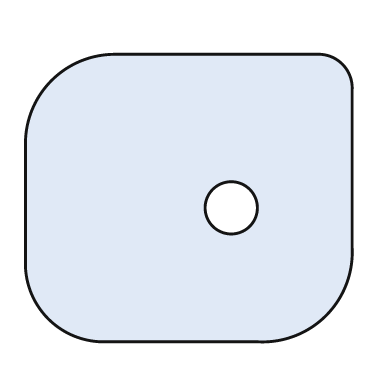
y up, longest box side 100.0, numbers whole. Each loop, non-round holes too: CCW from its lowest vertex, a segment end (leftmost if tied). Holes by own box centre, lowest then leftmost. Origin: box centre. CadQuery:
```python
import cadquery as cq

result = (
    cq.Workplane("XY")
    .moveTo(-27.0, -44.0)
    .lineTo(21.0, -44.0)
    .threePointArc((42.0, -36.0), (50.0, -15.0))
    .lineTo(50.0, 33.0)
    .threePointArc((47.0, 41.0), (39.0, 44.0))
    .lineTo(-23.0, 44.0)
    .threePointArc((-42.0, 36.0), (-50.0, 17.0))
    .lineTo(-50.0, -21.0)
    .threePointArc((-43.0, -37.0), (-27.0, -44.0))
    .close()
    .moveTo(13.0, -3.0)
    .circle(8.0)
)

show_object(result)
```